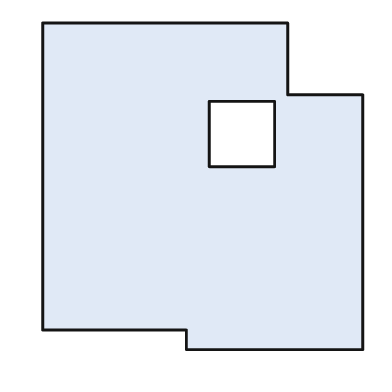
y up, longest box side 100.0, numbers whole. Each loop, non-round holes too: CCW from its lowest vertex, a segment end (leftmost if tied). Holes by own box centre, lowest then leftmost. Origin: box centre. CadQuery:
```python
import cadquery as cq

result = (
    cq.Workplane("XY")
    .moveTo(-5.0, -50.0)
    .lineTo(49.0, -50.0)
    .lineTo(49.0, 28.0)
    .lineTo(26.0, 28.0)
    .lineTo(26.0, 50.0)
    .lineTo(-49.0, 50.0)
    .lineTo(-49.0, -44.0)
    .lineTo(-5.0, -44.0)
    .close()
    .moveTo(2.0, 6.0)
    .lineTo(22.0, 6.0)
    .lineTo(22.0, 26.0)
    .lineTo(2.0, 26.0)
    .close()
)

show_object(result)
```